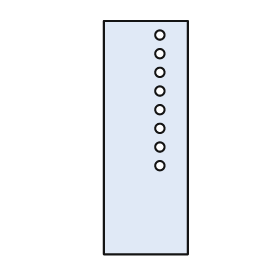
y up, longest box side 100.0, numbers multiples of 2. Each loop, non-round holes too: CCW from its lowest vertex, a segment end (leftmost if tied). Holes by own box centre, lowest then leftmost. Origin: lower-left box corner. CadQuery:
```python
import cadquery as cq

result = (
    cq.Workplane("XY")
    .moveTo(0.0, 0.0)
    .lineTo(36.0, 0.0)
    .lineTo(36.0, 100.0)
    .lineTo(0.0, 100.0)
    .close()
    .moveTo(24.0, 38.0)
    .circle(2.0)
    .moveTo(24.0, 46.0)
    .circle(2.0)
    .moveTo(24.0, 54.0)
    .circle(2.0)
    .moveTo(24.0, 62.0)
    .circle(2.0)
    .moveTo(24.0, 70.0)
    .circle(2.0)
    .moveTo(24.0, 78.0)
    .circle(2.0)
    .moveTo(24.0, 86.0)
    .circle(2.0)
    .moveTo(24.0, 94.0)
    .circle(2.0)
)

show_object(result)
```